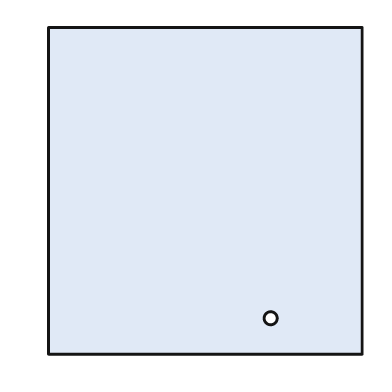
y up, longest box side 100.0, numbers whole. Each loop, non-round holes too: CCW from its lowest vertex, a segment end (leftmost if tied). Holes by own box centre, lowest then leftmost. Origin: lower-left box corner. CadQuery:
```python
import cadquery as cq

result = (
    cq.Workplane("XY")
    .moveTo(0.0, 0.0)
    .lineTo(96.0, 0.0)
    .lineTo(96.0, 100.0)
    .lineTo(0.0, 100.0)
    .close()
    .moveTo(68.0, 11.0)
    .circle(2.0)
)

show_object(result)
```